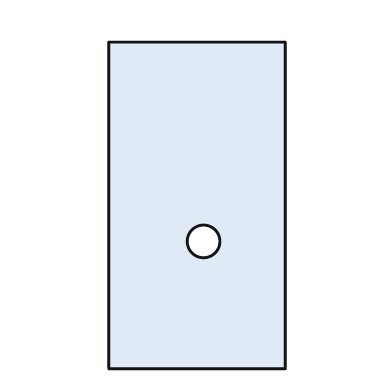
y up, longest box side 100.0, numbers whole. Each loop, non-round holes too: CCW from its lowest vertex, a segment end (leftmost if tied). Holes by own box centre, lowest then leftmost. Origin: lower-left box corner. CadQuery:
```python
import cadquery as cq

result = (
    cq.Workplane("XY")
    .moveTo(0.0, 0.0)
    .lineTo(54.0, 0.0)
    .lineTo(54.0, 100.0)
    .lineTo(0.0, 100.0)
    .close()
    .moveTo(29.0, 39.0)
    .circle(5.0)
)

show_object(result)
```